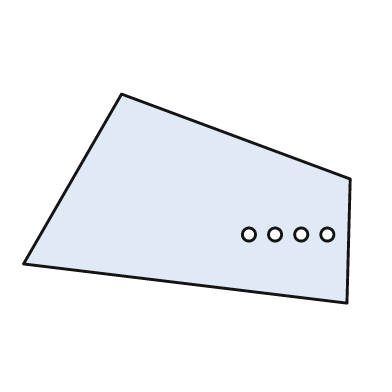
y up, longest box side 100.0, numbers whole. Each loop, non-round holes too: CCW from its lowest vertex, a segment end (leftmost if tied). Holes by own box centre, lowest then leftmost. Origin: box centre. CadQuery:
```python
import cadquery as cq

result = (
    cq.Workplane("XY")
    .moveTo(49.0, -32.0)
    .lineTo(50.0, 6.0)
    .lineTo(-20.0, 32.0)
    .lineTo(-50.0, -20.0)
    .close()
    .moveTo(19.0, -11.0)
    .circle(2.0)
    .moveTo(27.0, -11.0)
    .circle(2.0)
    .moveTo(35.0, -11.0)
    .circle(2.0)
    .moveTo(43.0, -11.0)
    .circle(2.0)
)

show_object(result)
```